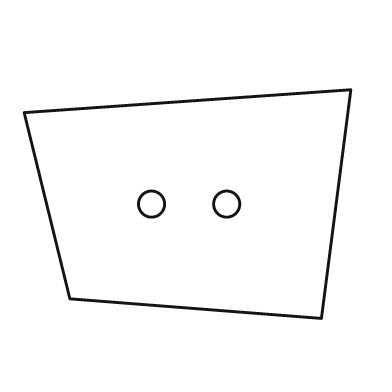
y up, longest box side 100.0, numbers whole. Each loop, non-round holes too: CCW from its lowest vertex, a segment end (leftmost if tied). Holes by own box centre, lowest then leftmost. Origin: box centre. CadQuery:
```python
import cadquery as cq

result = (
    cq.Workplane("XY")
    .moveTo(41.0, -35.0)
    .lineTo(50.0, 35.0)
    .lineTo(-50.0, 28.0)
    .lineTo(-36.0, -29.0)
    .close()
    .moveTo(-11.0, 0.0)
    .circle(4.0)
    .moveTo(12.0, 0.0)
    .circle(4.0)
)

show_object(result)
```